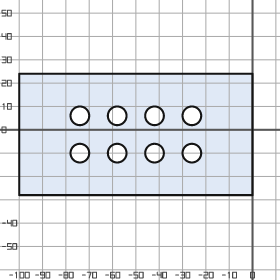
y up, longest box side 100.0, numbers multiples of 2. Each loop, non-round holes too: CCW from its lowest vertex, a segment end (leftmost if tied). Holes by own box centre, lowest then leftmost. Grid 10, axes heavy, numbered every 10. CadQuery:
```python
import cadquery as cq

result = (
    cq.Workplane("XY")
    .moveTo(-100.0, -28.0)
    .lineTo(0.0, -28.0)
    .lineTo(0.0, 24.0)
    .lineTo(-100.0, 24.0)
    .close()
    .moveTo(-74.0, -10.0)
    .circle(4.0)
    .moveTo(-58.0, -10.0)
    .circle(4.0)
    .moveTo(-42.0, -10.0)
    .circle(4.0)
    .moveTo(-26.0, -10.0)
    .circle(4.0)
    .moveTo(-74.0, 6.0)
    .circle(4.0)
    .moveTo(-58.0, 6.0)
    .circle(4.0)
    .moveTo(-42.0, 6.0)
    .circle(4.0)
    .moveTo(-26.0, 6.0)
    .circle(4.0)
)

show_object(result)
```